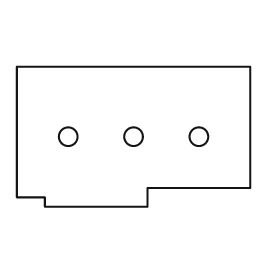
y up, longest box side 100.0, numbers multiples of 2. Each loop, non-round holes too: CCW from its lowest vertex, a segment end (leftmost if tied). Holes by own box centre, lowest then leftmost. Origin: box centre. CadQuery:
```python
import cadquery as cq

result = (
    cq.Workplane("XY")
    .moveTo(-38.0, -30.0)
    .lineTo(6.0, -30.0)
    .lineTo(6.0, -22.0)
    .lineTo(50.0, -22.0)
    .lineTo(50.0, 30.0)
    .lineTo(-50.0, 30.0)
    .lineTo(-50.0, -26.0)
    .lineTo(-38.0, -26.0)
    .close()
    .moveTo(-28.0, 0.0)
    .circle(4.0)
    .moveTo(0.0, 0.0)
    .circle(4.0)
    .moveTo(28.0, 0.0)
    .circle(4.0)
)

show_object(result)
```